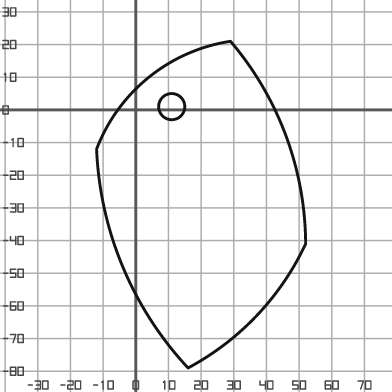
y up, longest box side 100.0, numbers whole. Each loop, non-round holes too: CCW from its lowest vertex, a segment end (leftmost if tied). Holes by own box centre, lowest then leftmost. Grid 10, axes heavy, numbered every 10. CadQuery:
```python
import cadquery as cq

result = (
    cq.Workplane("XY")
    .moveTo(16.0, -79.0)
    .threePointArc((37.0, -63.0), (52.0, -41.0))
    .threePointArc((46.0, -8.0), (29.0, 21.0))
    .threePointArc((4.0, 10.0), (-12.0, -12.0))
    .threePointArc((-4.0, -48.0), (16.0, -79.0))
    .close()
    .moveTo(11.0, 1.0)
    .circle(4.0)
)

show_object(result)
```